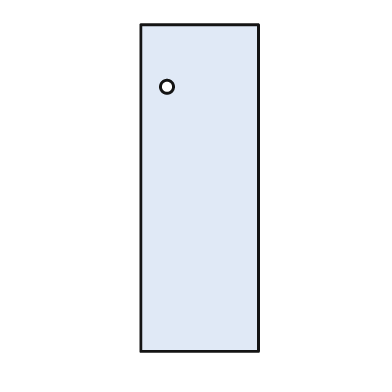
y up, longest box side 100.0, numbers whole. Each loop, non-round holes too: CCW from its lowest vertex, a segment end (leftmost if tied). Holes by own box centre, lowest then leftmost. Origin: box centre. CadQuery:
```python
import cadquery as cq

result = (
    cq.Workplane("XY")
    .moveTo(-18.0, -50.0)
    .lineTo(18.0, -50.0)
    .lineTo(18.0, 50.0)
    .lineTo(-18.0, 50.0)
    .close()
    .moveTo(-10.0, 31.0)
    .circle(2.0)
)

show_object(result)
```